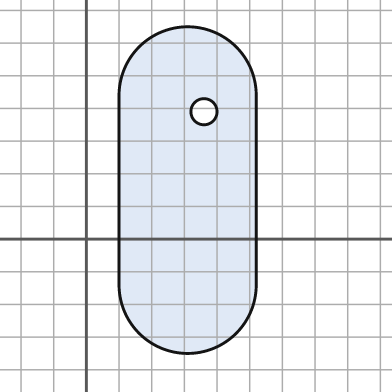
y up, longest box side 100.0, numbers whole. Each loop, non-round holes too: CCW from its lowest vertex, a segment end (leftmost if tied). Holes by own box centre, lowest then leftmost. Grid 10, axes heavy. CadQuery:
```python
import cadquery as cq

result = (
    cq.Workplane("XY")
    .moveTo(10.0, -14.0)
    .threePointArc((31.0, -35.0), (52.0, -14.0))
    .lineTo(52.0, 44.0)
    .threePointArc((31.0, 65.0), (10.0, 44.0))
    .close()
    .moveTo(36.0, 39.0)
    .circle(4.0)
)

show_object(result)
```